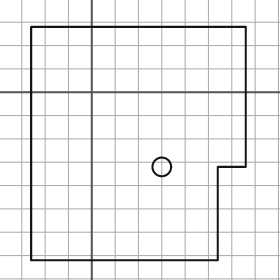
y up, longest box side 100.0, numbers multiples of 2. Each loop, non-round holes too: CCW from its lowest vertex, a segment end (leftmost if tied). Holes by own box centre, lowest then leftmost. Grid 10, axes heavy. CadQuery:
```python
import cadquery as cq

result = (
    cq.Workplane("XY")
    .moveTo(-26.0, -72.0)
    .lineTo(54.0, -72.0)
    .lineTo(54.0, -32.0)
    .lineTo(66.0, -32.0)
    .lineTo(66.0, 28.0)
    .lineTo(-26.0, 28.0)
    .close()
    .moveTo(30.0, -32.0)
    .circle(4.0)
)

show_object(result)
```